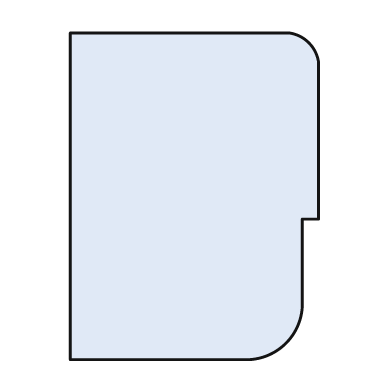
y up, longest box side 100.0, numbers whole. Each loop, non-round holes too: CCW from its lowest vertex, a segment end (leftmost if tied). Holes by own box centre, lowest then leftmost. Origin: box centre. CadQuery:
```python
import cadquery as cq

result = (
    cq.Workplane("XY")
    .moveTo(-38.0, -50.0)
    .lineTo(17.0, -50.0)
    .threePointArc((28.0, -45.0), (33.0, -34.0))
    .lineTo(33.0, -7.0)
    .lineTo(38.0, -7.0)
    .lineTo(38.0, 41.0)
    .threePointArc((35.0, 47.0), (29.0, 50.0))
    .lineTo(-38.0, 50.0)
    .close()
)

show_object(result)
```